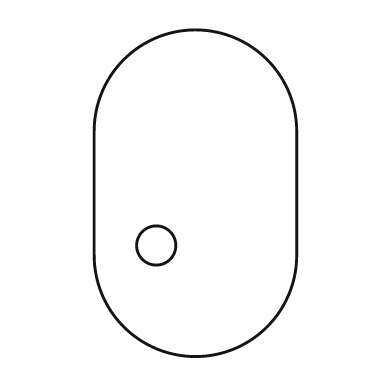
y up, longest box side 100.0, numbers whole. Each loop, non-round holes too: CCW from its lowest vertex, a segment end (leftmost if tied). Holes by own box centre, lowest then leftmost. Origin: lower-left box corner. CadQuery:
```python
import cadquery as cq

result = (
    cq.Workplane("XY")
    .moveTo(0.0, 31.0)
    .threePointArc((31.0, 0.0), (62.0, 31.0))
    .lineTo(62.0, 69.0)
    .threePointArc((31.0, 100.0), (0.0, 69.0))
    .close()
    .moveTo(19.0, 34.0)
    .circle(6.0)
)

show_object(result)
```